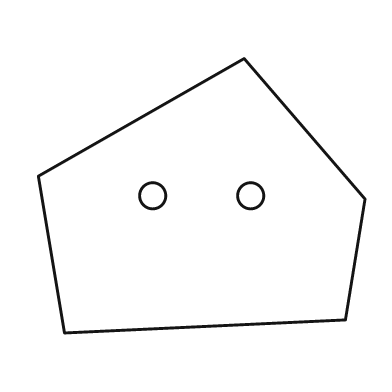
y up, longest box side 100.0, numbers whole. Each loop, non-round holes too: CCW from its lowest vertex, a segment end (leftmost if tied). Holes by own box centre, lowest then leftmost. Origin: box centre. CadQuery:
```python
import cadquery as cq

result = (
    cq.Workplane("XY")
    .moveTo(-42.0, -42.0)
    .lineTo(44.0, -38.0)
    .lineTo(50.0, -1.0)
    .lineTo(13.0, 42.0)
    .lineTo(-50.0, 6.0)
    .close()
    .moveTo(-15.0, 0.0)
    .circle(4.0)
    .moveTo(15.0, 0.0)
    .circle(4.0)
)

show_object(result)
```